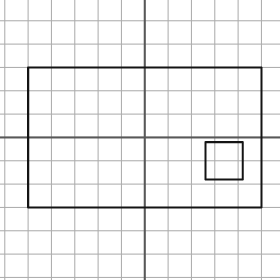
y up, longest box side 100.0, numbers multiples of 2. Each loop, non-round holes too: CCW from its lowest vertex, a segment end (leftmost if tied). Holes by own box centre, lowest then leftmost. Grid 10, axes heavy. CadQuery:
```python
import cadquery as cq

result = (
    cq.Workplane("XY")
    .moveTo(-50.0, -30.0)
    .lineTo(50.0, -30.0)
    .lineTo(50.0, 30.0)
    .lineTo(-50.0, 30.0)
    .close()
    .moveTo(26.0, -18.0)
    .lineTo(42.0, -18.0)
    .lineTo(42.0, -2.0)
    .lineTo(26.0, -2.0)
    .close()
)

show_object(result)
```